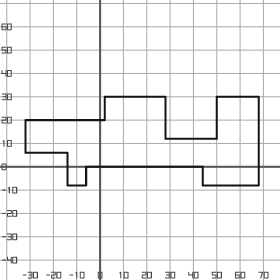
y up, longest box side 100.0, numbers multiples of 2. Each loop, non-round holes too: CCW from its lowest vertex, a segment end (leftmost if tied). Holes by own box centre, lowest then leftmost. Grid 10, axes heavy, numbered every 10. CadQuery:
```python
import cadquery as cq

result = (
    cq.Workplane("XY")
    .moveTo(-14.0, -8.0)
    .lineTo(-6.0, -8.0)
    .lineTo(-6.0, 0.0)
    .lineTo(44.0, 0.0)
    .lineTo(44.0, -8.0)
    .lineTo(68.0, -8.0)
    .lineTo(68.0, 30.0)
    .lineTo(50.0, 30.0)
    .lineTo(50.0, 12.0)
    .lineTo(28.0, 12.0)
    .lineTo(28.0, 30.0)
    .lineTo(2.0, 30.0)
    .lineTo(2.0, 20.0)
    .lineTo(-32.0, 20.0)
    .lineTo(-32.0, 6.0)
    .lineTo(-14.0, 6.0)
    .close()
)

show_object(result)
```